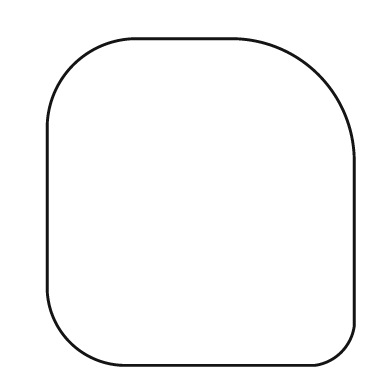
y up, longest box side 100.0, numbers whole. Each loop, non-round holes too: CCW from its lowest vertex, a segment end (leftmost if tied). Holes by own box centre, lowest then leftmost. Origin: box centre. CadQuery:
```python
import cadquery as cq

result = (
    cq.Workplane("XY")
    .moveTo(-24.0, -50.0)
    .lineTo(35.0, -50.0)
    .threePointArc((43.0, -46.0), (47.0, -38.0))
    .lineTo(47.0, 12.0)
    .threePointArc((36.0, 39.0), (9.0, 50.0))
    .lineTo(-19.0, 50.0)
    .threePointArc((-39.0, 42.0), (-47.0, 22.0))
    .lineTo(-47.0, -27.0)
    .threePointArc((-40.0, -43.0), (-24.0, -50.0))
    .close()
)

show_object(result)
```